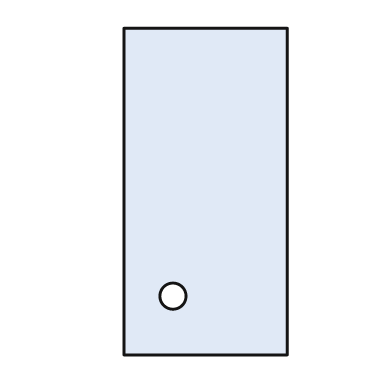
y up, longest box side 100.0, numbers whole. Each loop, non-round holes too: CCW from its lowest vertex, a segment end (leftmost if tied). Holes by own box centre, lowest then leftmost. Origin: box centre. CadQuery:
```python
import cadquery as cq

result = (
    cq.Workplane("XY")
    .moveTo(-25.0, -50.0)
    .lineTo(25.0, -50.0)
    .lineTo(25.0, 50.0)
    .lineTo(-25.0, 50.0)
    .close()
    .moveTo(-10.0, -32.0)
    .circle(4.0)
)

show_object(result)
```